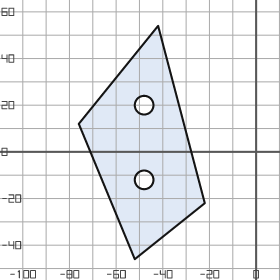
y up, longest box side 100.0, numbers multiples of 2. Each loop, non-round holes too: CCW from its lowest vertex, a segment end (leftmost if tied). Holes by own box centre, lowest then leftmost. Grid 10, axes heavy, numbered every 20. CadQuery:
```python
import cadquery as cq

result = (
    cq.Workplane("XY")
    .moveTo(-52.0, -46.0)
    .lineTo(-22.0, -22.0)
    .lineTo(-42.0, 54.0)
    .lineTo(-76.0, 12.0)
    .close()
    .moveTo(-48.0, -12.0)
    .circle(4.0)
    .moveTo(-48.0, 20.0)
    .circle(4.0)
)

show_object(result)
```